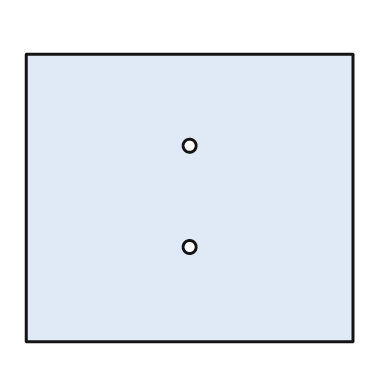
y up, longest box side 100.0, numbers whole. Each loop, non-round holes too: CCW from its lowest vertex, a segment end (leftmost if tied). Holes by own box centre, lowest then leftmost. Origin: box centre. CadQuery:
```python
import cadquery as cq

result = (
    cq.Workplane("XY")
    .moveTo(-50.0, -44.0)
    .lineTo(50.0, -44.0)
    .lineTo(50.0, 44.0)
    .lineTo(-50.0, 44.0)
    .close()
    .moveTo(0.0, -15.0)
    .circle(2.0)
    .moveTo(0.0, 16.0)
    .circle(2.0)
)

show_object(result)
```